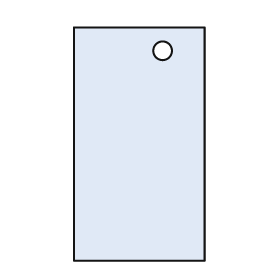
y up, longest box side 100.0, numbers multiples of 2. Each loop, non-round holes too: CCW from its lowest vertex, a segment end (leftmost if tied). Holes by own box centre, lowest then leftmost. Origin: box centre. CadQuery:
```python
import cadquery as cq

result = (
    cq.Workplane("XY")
    .moveTo(-28.0, -50.0)
    .lineTo(28.0, -50.0)
    .lineTo(28.0, 50.0)
    .lineTo(-28.0, 50.0)
    .close()
    .moveTo(10.0, 40.0)
    .circle(4.0)
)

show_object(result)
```